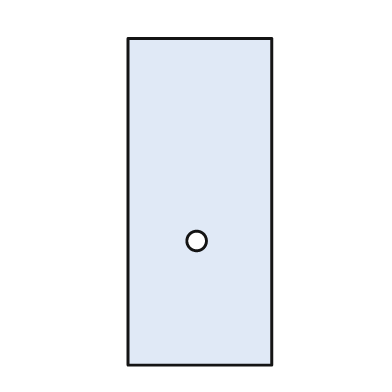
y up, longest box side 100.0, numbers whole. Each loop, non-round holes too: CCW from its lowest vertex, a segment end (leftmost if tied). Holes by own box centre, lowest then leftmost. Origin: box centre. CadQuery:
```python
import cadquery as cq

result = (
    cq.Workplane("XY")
    .moveTo(-22.0, -50.0)
    .lineTo(22.0, -50.0)
    .lineTo(22.0, 50.0)
    .lineTo(-22.0, 50.0)
    .close()
    .moveTo(-1.0, -12.0)
    .circle(3.0)
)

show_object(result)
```